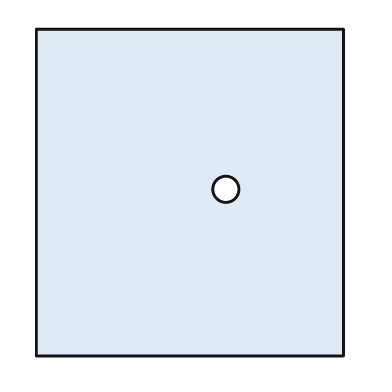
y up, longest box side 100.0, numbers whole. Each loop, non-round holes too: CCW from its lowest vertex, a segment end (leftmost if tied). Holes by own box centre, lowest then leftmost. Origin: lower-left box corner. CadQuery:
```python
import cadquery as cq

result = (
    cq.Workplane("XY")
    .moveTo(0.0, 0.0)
    .lineTo(94.0, 0.0)
    .lineTo(94.0, 100.0)
    .lineTo(0.0, 100.0)
    .close()
    .moveTo(58.0, 51.0)
    .circle(4.0)
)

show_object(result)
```